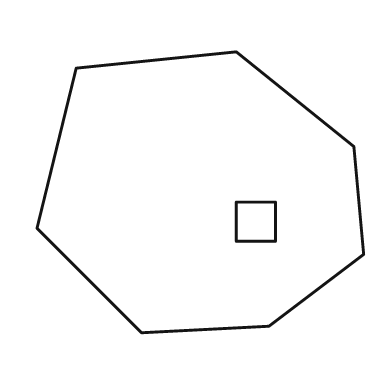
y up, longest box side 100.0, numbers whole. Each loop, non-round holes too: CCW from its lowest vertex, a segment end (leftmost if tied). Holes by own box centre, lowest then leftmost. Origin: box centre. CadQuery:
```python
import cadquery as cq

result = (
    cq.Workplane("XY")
    .moveTo(-18.0, -43.0)
    .lineTo(21.0, -41.0)
    .lineTo(50.0, -19.0)
    .lineTo(47.0, 14.0)
    .lineTo(11.0, 43.0)
    .lineTo(-38.0, 38.0)
    .lineTo(-50.0, -11.0)
    .close()
    .moveTo(11.0, -15.0)
    .lineTo(23.0, -15.0)
    .lineTo(23.0, -3.0)
    .lineTo(11.0, -3.0)
    .close()
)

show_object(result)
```